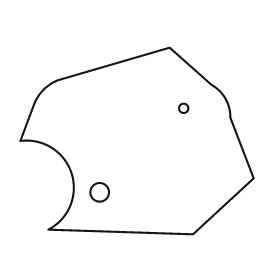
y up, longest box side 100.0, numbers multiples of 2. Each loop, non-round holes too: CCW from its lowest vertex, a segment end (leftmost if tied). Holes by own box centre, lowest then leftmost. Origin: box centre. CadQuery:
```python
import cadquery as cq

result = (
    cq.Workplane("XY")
    .moveTo(24.0, -40.0)
    .lineTo(50.0, -16.0)
    .lineTo(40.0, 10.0)
    .threePointArc((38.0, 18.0), (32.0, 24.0))
    .lineTo(14.0, 40.0)
    .lineTo(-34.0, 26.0)
    .threePointArc((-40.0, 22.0), (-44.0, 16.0))
    .lineTo(-50.0, 0.0)
    .threePointArc((-28.0, -14.0), (-38.0, -38.0))
    .close()
    .moveTo(-16.0, -22.0)
    .circle(4.0)
    .moveTo(20.0, 14.0)
    .circle(2.0)
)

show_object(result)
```